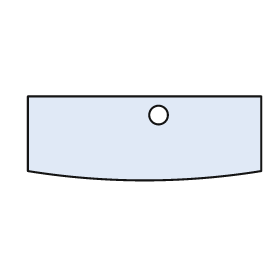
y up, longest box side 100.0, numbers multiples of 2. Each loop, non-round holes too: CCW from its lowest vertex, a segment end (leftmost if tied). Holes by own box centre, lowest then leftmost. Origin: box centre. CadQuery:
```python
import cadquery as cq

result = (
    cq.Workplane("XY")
    .moveTo(-50.0, -14.0)
    .threePointArc((0.0, -18.0), (50.0, -14.0))
    .lineTo(50.0, 18.0)
    .lineTo(-50.0, 18.0)
    .close()
    .moveTo(6.0, 10.0)
    .circle(4.0)
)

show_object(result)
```